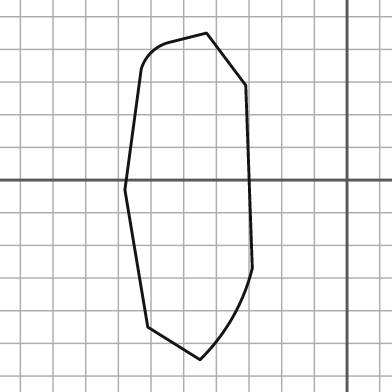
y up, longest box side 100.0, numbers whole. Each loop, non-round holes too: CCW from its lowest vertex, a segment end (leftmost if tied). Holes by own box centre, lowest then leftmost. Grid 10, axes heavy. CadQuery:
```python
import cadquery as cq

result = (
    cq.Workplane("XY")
    .moveTo(-45.0, -55.0)
    .threePointArc((-35.0, -42.0), (-29.0, -27.0))
    .lineTo(-31.0, 29.0)
    .lineTo(-43.0, 45.0)
    .lineTo(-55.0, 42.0)
    .threePointArc((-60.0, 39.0), (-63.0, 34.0))
    .lineTo(-68.0, -3.0)
    .lineTo(-61.0, -45.0)
    .close()
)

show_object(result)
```